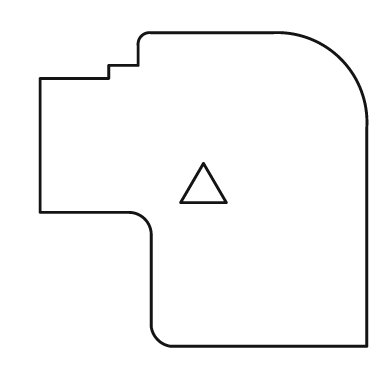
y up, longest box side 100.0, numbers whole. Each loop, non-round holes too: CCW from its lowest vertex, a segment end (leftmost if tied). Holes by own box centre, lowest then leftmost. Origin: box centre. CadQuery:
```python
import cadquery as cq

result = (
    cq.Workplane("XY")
    .moveTo(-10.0, -48.0)
    .lineTo(50.0, -48.0)
    .lineTo(50.0, 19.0)
    .threePointArc((42.0, 40.0), (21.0, 48.0))
    .lineTo(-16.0, 48.0)
    .threePointArc((-19.0, 47.0), (-20.0, 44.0))
    .lineTo(-20.0, 38.0)
    .lineTo(-29.0, 38.0)
    .lineTo(-29.0, 34.0)
    .lineTo(-50.0, 34.0)
    .lineTo(-50.0, -7.0)
    .lineTo(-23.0, -7.0)
    .threePointArc((-18.0, -9.0), (-16.0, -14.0))
    .lineTo(-16.0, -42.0)
    .threePointArc((-14.0, -46.0), (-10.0, -48.0))
    .close()
    .moveTo(-7.0, -4.0)
    .lineTo(7.0, -4.0)
    .lineTo(0.0, 8.0)
    .close()
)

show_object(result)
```